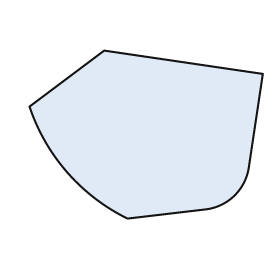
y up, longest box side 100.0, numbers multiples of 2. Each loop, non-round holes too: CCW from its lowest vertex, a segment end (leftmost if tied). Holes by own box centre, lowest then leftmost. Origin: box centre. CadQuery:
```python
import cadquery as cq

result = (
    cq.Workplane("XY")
    .moveTo(-8.0, -36.0)
    .lineTo(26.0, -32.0)
    .threePointArc((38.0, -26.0), (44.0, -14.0))
    .lineTo(50.0, 26.0)
    .lineTo(-18.0, 36.0)
    .lineTo(-50.0, 12.0)
    .threePointArc((-34.0, -16.0), (-8.0, -36.0))
    .close()
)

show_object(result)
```